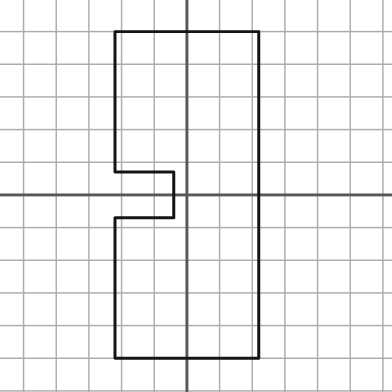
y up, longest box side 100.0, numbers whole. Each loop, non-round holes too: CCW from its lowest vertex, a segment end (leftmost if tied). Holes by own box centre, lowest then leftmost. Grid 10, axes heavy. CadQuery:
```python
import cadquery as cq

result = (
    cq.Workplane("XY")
    .moveTo(-22.0, -50.0)
    .lineTo(22.0, -50.0)
    .lineTo(22.0, 50.0)
    .lineTo(-22.0, 50.0)
    .lineTo(-22.0, 7.0)
    .lineTo(-4.0, 7.0)
    .lineTo(-4.0, -7.0)
    .lineTo(-22.0, -7.0)
    .close()
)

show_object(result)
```